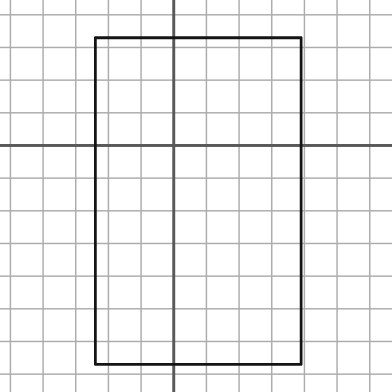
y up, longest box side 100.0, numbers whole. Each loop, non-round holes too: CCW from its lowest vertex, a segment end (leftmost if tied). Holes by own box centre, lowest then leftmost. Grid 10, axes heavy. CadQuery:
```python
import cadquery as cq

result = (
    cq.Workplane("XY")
    .moveTo(-24.0, -67.0)
    .lineTo(39.0, -67.0)
    .lineTo(39.0, 33.0)
    .lineTo(-24.0, 33.0)
    .close()
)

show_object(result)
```